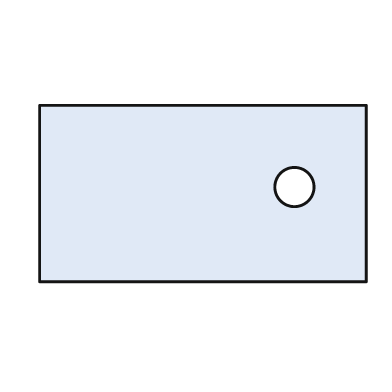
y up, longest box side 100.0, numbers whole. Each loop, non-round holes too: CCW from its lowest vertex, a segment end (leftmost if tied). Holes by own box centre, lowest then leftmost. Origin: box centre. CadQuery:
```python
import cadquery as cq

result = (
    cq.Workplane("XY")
    .moveTo(-50.0, -27.0)
    .lineTo(50.0, -27.0)
    .lineTo(50.0, 27.0)
    .lineTo(-50.0, 27.0)
    .close()
    .moveTo(28.0, 2.0)
    .circle(6.0)
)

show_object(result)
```